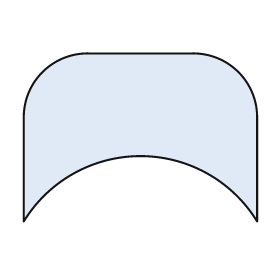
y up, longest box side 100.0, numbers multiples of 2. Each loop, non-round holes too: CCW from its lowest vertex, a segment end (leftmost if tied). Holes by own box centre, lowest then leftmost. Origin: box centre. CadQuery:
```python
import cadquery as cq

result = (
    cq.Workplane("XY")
    .moveTo(-50.0, -36.0)
    .threePointArc((0.0, -8.0), (50.0, -36.0))
    .lineTo(50.0, 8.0)
    .threePointArc((42.0, 28.0), (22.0, 36.0))
    .lineTo(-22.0, 36.0)
    .threePointArc((-42.0, 28.0), (-50.0, 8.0))
    .close()
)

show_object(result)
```